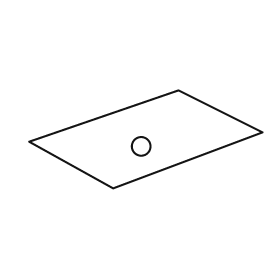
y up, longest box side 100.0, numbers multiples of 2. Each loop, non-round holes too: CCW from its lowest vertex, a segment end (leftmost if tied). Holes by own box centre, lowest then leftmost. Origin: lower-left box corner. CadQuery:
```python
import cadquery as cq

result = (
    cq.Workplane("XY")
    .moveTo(36.0, 0.0)
    .lineTo(100.0, 24.0)
    .lineTo(64.0, 42.0)
    .lineTo(0.0, 20.0)
    .close()
    .moveTo(48.0, 18.0)
    .circle(4.0)
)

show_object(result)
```